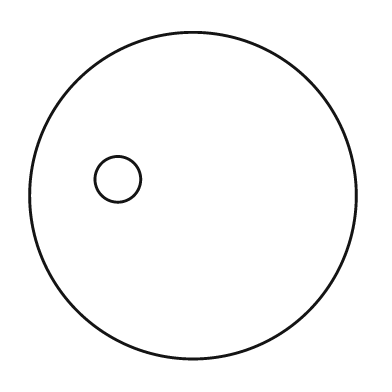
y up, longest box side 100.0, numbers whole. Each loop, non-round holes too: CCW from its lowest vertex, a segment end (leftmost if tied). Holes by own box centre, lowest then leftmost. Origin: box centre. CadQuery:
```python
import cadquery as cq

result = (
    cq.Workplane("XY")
    .moveTo(0.0, 0.0)
    .circle(50.0)
    .moveTo(-23.0, 5.0)
    .circle(7.0)
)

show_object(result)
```